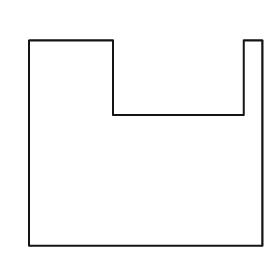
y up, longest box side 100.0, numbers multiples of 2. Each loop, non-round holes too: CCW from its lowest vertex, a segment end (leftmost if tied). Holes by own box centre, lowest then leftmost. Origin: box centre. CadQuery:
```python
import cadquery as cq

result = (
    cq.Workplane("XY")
    .moveTo(-50.0, -44.0)
    .lineTo(50.0, -44.0)
    .lineTo(50.0, 44.0)
    .lineTo(42.0, 44.0)
    .lineTo(42.0, 12.0)
    .lineTo(-14.0, 12.0)
    .lineTo(-14.0, 44.0)
    .lineTo(-50.0, 44.0)
    .close()
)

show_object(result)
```